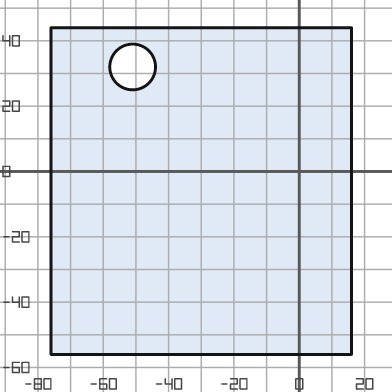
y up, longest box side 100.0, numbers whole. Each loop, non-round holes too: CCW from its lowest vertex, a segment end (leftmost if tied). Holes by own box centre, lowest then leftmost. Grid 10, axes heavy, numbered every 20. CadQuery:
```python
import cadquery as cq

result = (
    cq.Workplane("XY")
    .moveTo(-76.0, -56.0)
    .lineTo(16.0, -56.0)
    .lineTo(16.0, 44.0)
    .lineTo(-76.0, 44.0)
    .close()
    .moveTo(-51.0, 32.0)
    .circle(7.0)
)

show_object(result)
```